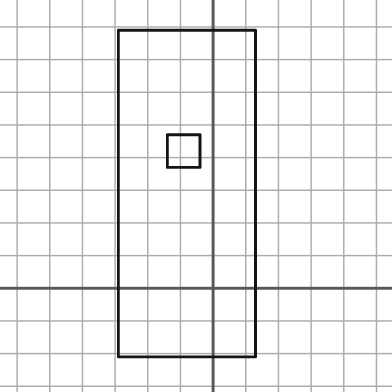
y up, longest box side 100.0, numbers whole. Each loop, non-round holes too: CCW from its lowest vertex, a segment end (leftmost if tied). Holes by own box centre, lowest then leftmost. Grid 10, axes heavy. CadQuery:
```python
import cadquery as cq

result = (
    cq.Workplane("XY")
    .moveTo(-29.0, -21.0)
    .lineTo(13.0, -21.0)
    .lineTo(13.0, 79.0)
    .lineTo(-29.0, 79.0)
    .close()
    .moveTo(-14.0, 37.0)
    .lineTo(-4.0, 37.0)
    .lineTo(-4.0, 47.0)
    .lineTo(-14.0, 47.0)
    .close()
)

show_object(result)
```